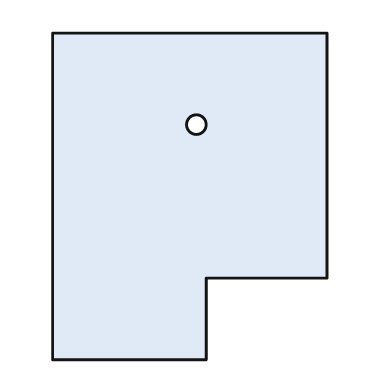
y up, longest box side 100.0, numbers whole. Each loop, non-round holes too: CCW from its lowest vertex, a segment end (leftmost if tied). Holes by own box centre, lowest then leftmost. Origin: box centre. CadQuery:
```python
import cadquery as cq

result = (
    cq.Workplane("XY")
    .moveTo(-42.0, -50.0)
    .lineTo(5.0, -50.0)
    .lineTo(5.0, -25.0)
    .lineTo(42.0, -25.0)
    .lineTo(42.0, 50.0)
    .lineTo(-42.0, 50.0)
    .close()
    .moveTo(2.0, 22.0)
    .circle(3.0)
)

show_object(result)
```